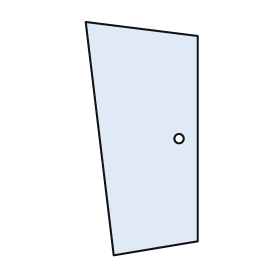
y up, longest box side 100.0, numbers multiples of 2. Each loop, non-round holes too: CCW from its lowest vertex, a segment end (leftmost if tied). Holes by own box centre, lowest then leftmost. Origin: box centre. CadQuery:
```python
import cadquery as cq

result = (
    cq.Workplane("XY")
    .moveTo(-12.0, -50.0)
    .lineTo(24.0, -44.0)
    .lineTo(24.0, 44.0)
    .lineTo(-24.0, 50.0)
    .close()
    .moveTo(16.0, 0.0)
    .circle(2.0)
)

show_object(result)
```